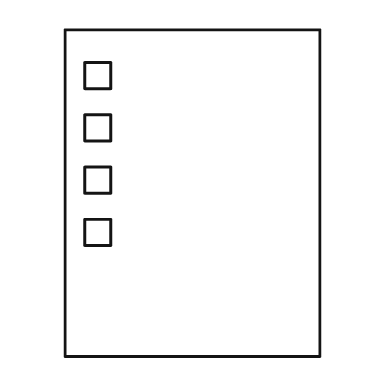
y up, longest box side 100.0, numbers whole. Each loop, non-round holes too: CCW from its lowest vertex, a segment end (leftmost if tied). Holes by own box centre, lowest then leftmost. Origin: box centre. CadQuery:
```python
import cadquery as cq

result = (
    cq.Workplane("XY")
    .moveTo(-39.0, -50.0)
    .lineTo(39.0, -50.0)
    .lineTo(39.0, 50.0)
    .lineTo(-39.0, 50.0)
    .close()
    .moveTo(-33.0, -16.0)
    .lineTo(-25.0, -16.0)
    .lineTo(-25.0, -8.0)
    .lineTo(-33.0, -8.0)
    .close()
    .moveTo(-33.0, 0.0)
    .lineTo(-25.0, 0.0)
    .lineTo(-25.0, 8.0)
    .lineTo(-33.0, 8.0)
    .close()
    .moveTo(-33.0, 16.0)
    .lineTo(-25.0, 16.0)
    .lineTo(-25.0, 24.0)
    .lineTo(-33.0, 24.0)
    .close()
    .moveTo(-33.0, 32.0)
    .lineTo(-25.0, 32.0)
    .lineTo(-25.0, 40.0)
    .lineTo(-33.0, 40.0)
    .close()
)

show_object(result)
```